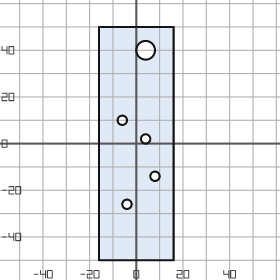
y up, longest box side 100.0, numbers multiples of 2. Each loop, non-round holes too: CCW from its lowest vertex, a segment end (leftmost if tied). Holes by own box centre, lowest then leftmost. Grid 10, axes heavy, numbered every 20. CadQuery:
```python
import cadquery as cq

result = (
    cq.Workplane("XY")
    .moveTo(-16.0, -50.0)
    .lineTo(16.0, -50.0)
    .lineTo(16.0, 50.0)
    .lineTo(-16.0, 50.0)
    .close()
    .moveTo(-4.0, -26.0)
    .circle(2.0)
    .moveTo(8.0, -14.0)
    .circle(2.0)
    .moveTo(4.0, 2.0)
    .circle(2.0)
    .moveTo(-6.0, 10.0)
    .circle(2.0)
    .moveTo(4.0, 40.0)
    .circle(4.0)
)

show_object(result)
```